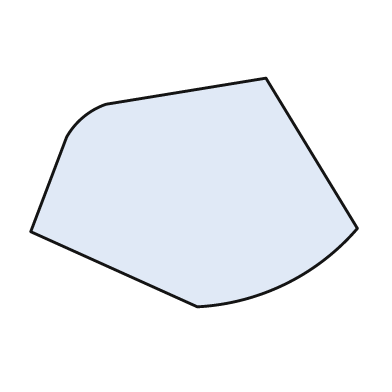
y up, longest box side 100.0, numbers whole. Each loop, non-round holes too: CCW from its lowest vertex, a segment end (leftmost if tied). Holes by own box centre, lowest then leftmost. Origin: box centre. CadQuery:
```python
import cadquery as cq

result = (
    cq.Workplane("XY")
    .moveTo(1.0, -35.0)
    .threePointArc((28.0, -28.0), (50.0, -11.0))
    .lineTo(22.0, 35.0)
    .lineTo(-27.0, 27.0)
    .threePointArc((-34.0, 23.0), (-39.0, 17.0))
    .lineTo(-50.0, -12.0)
    .close()
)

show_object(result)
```